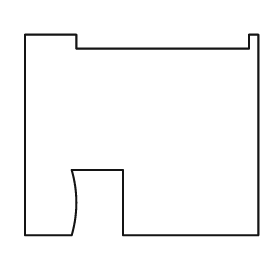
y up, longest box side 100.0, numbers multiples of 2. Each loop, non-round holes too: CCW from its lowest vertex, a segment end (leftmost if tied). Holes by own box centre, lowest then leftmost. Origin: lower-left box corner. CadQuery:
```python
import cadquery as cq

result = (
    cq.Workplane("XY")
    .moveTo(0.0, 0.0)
    .lineTo(20.0, 0.0)
    .threePointArc((22.0, 14.0), (20.0, 28.0))
    .lineTo(42.0, 28.0)
    .lineTo(42.0, 0.0)
    .lineTo(100.0, 0.0)
    .lineTo(100.0, 86.0)
    .lineTo(96.0, 86.0)
    .lineTo(96.0, 80.0)
    .lineTo(22.0, 80.0)
    .lineTo(22.0, 86.0)
    .lineTo(0.0, 86.0)
    .close()
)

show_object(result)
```